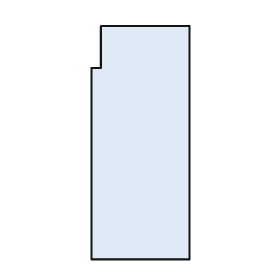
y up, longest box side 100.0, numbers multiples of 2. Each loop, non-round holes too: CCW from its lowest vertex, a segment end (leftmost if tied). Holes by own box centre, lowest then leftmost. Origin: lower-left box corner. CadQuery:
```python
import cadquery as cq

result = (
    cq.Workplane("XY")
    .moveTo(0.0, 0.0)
    .lineTo(42.0, 0.0)
    .lineTo(42.0, 100.0)
    .lineTo(4.0, 100.0)
    .lineTo(4.0, 82.0)
    .lineTo(0.0, 82.0)
    .close()
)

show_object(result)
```